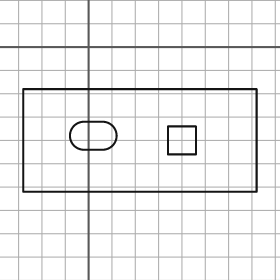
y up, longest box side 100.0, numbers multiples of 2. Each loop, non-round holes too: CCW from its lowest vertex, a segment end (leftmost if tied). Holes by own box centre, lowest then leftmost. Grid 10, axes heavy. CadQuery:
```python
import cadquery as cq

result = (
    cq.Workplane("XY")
    .moveTo(-28.0, -62.0)
    .lineTo(72.0, -62.0)
    .lineTo(72.0, -18.0)
    .lineTo(-28.0, -18.0)
    .close()
    .moveTo(34.0, -46.0)
    .lineTo(46.0, -46.0)
    .lineTo(46.0, -34.0)
    .lineTo(34.0, -34.0)
    .close()
    .moveTo(-2.0, -44.0)
    .lineTo(6.0, -44.0)
    .threePointArc((12.0, -38.0), (6.0, -32.0))
    .lineTo(-2.0, -32.0)
    .threePointArc((-8.0, -38.0), (-2.0, -44.0))
    .close()
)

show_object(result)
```